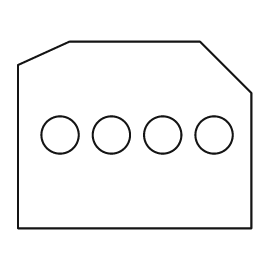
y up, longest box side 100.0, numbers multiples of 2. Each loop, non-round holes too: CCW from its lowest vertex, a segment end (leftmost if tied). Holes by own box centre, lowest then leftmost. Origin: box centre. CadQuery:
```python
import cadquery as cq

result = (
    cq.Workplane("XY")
    .moveTo(-50.0, -40.0)
    .lineTo(50.0, -40.0)
    .lineTo(50.0, 18.0)
    .lineTo(28.0, 40.0)
    .lineTo(-28.0, 40.0)
    .lineTo(-50.0, 30.0)
    .close()
    .moveTo(-32.0, 0.0)
    .circle(8.0)
    .moveTo(-10.0, 0.0)
    .circle(8.0)
    .moveTo(12.0, 0.0)
    .circle(8.0)
    .moveTo(34.0, 0.0)
    .circle(8.0)
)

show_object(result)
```